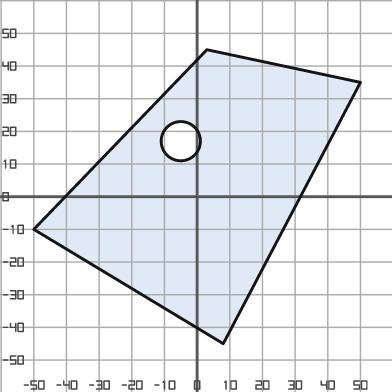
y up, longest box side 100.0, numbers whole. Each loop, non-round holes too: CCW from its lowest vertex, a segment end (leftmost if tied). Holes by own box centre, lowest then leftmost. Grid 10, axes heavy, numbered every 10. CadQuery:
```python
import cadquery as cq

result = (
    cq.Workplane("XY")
    .moveTo(8.0, -45.0)
    .lineTo(50.0, 35.0)
    .lineTo(3.0, 45.0)
    .lineTo(-50.0, -10.0)
    .close()
    .moveTo(-5.0, 17.0)
    .circle(6.0)
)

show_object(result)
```